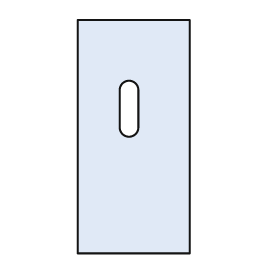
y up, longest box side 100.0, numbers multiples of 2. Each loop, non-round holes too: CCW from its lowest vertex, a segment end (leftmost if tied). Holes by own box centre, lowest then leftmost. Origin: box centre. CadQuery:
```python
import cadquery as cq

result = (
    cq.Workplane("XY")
    .moveTo(-24.0, -50.0)
    .lineTo(24.0, -50.0)
    .lineTo(24.0, 50.0)
    .lineTo(-24.0, 50.0)
    .close()
    .moveTo(-6.0, 4.0)
    .threePointArc((-2.0, 0.0), (2.0, 4.0))
    .lineTo(2.0, 20.0)
    .threePointArc((-2.0, 24.0), (-6.0, 20.0))
    .close()
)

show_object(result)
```